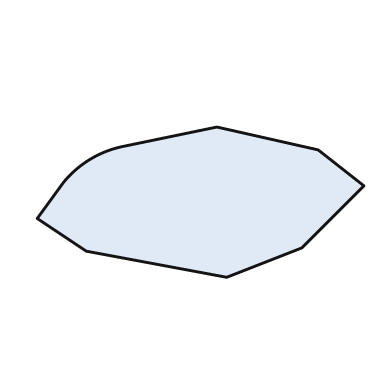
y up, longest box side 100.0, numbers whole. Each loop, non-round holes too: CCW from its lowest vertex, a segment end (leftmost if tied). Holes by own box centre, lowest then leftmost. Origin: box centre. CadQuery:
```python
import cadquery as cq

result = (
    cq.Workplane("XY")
    .moveTo(8.0, -23.0)
    .lineTo(31.0, -14.0)
    .lineTo(50.0, 5.0)
    .lineTo(36.0, 16.0)
    .lineTo(5.0, 23.0)
    .lineTo(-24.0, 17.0)
    .threePointArc((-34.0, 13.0), (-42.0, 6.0))
    .lineTo(-50.0, -5.0)
    .lineTo(-35.0, -15.0)
    .close()
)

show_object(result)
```